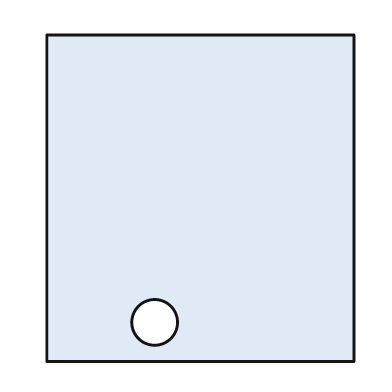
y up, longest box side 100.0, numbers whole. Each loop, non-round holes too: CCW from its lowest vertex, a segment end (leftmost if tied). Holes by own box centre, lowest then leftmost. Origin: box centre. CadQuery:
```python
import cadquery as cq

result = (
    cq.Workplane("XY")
    .moveTo(-47.0, -50.0)
    .lineTo(47.0, -50.0)
    .lineTo(47.0, 50.0)
    .lineTo(-47.0, 50.0)
    .close()
    .moveTo(-14.0, -38.0)
    .circle(7.0)
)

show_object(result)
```